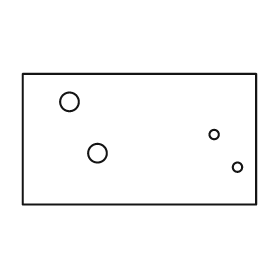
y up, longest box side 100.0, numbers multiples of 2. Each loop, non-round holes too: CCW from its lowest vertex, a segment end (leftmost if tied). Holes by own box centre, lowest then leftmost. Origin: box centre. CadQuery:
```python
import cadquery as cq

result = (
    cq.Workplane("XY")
    .moveTo(-50.0, -28.0)
    .lineTo(50.0, -28.0)
    .lineTo(50.0, 28.0)
    .lineTo(-50.0, 28.0)
    .close()
    .moveTo(42.0, -12.0)
    .circle(2.0)
    .moveTo(-18.0, -6.0)
    .circle(4.0)
    .moveTo(32.0, 2.0)
    .circle(2.0)
    .moveTo(-30.0, 16.0)
    .circle(4.0)
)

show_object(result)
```